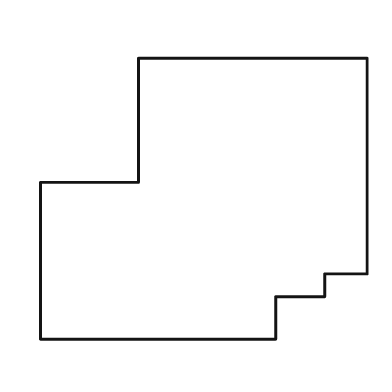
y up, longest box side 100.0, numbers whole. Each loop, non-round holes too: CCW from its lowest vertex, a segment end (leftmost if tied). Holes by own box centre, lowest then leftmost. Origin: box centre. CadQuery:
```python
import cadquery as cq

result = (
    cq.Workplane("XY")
    .moveTo(-50.0, -43.0)
    .lineTo(22.0, -43.0)
    .lineTo(22.0, -30.0)
    .lineTo(37.0, -30.0)
    .lineTo(37.0, -23.0)
    .lineTo(50.0, -23.0)
    .lineTo(50.0, 43.0)
    .lineTo(-20.0, 43.0)
    .lineTo(-20.0, 5.0)
    .lineTo(-50.0, 5.0)
    .close()
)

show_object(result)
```